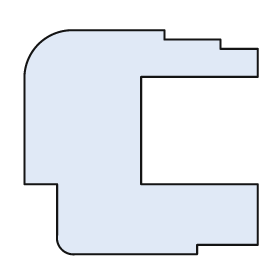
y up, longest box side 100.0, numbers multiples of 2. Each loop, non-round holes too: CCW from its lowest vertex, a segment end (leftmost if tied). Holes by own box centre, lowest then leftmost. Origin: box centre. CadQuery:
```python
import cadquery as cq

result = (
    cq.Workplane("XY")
    .moveTo(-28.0, -48.0)
    .lineTo(24.0, -48.0)
    .lineTo(24.0, -44.0)
    .lineTo(50.0, -44.0)
    .lineTo(50.0, -18.0)
    .lineTo(0.0, -18.0)
    .lineTo(0.0, 28.0)
    .lineTo(50.0, 28.0)
    .lineTo(50.0, 40.0)
    .lineTo(34.0, 40.0)
    .lineTo(34.0, 44.0)
    .lineTo(10.0, 44.0)
    .lineTo(10.0, 48.0)
    .lineTo(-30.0, 48.0)
    .threePointArc((-44.0, 42.0), (-50.0, 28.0))
    .lineTo(-50.0, -18.0)
    .lineTo(-36.0, -18.0)
    .lineTo(-36.0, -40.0)
    .threePointArc((-34.0, -46.0), (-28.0, -48.0))
    .close()
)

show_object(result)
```